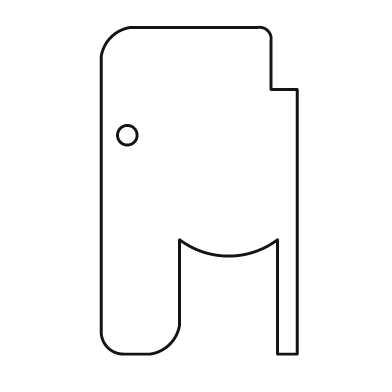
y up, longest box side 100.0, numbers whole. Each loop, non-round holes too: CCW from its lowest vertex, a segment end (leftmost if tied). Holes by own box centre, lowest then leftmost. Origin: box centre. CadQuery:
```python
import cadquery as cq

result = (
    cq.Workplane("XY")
    .moveTo(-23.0, -50.0)
    .lineTo(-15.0, -50.0)
    .threePointArc((-9.0, -47.0), (-6.0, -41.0))
    .lineTo(-6.0, -15.0)
    .threePointArc((9.0, -20.0), (24.0, -15.0))
    .lineTo(24.0, -50.0)
    .lineTo(30.0, -50.0)
    .lineTo(30.0, 31.0)
    .lineTo(22.0, 31.0)
    .lineTo(22.0, 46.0)
    .threePointArc((21.0, 49.0), (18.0, 50.0))
    .lineTo(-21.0, 50.0)
    .threePointArc((-27.0, 47.0), (-30.0, 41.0))
    .lineTo(-30.0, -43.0)
    .threePointArc((-28.0, -48.0), (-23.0, -50.0))
    .close()
    .moveTo(-22.0, 17.0)
    .circle(3.0)
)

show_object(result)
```